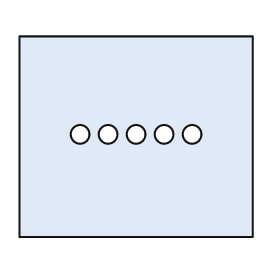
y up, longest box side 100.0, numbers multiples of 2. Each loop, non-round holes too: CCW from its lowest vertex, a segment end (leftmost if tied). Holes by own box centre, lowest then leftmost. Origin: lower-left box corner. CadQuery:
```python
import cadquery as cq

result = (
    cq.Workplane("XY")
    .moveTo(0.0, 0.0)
    .lineTo(100.0, 0.0)
    .lineTo(100.0, 86.0)
    .lineTo(0.0, 86.0)
    .close()
    .moveTo(26.0, 44.0)
    .circle(4.0)
    .moveTo(38.0, 44.0)
    .circle(4.0)
    .moveTo(50.0, 44.0)
    .circle(4.0)
    .moveTo(62.0, 44.0)
    .circle(4.0)
    .moveTo(74.0, 44.0)
    .circle(4.0)
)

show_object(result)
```